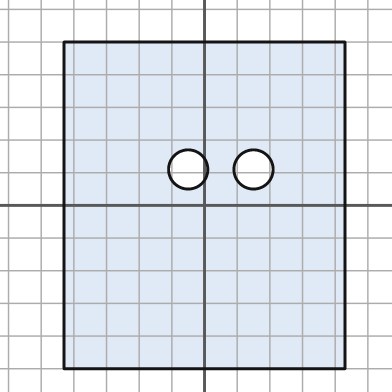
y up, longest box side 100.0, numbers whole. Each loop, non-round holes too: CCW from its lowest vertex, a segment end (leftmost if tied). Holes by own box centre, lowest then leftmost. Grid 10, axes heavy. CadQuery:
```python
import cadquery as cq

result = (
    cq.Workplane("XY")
    .moveTo(-43.0, -50.0)
    .lineTo(43.0, -50.0)
    .lineTo(43.0, 50.0)
    .lineTo(-43.0, 50.0)
    .close()
    .moveTo(-5.0, 11.0)
    .circle(6.0)
    .moveTo(15.0, 11.0)
    .circle(6.0)
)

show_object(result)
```